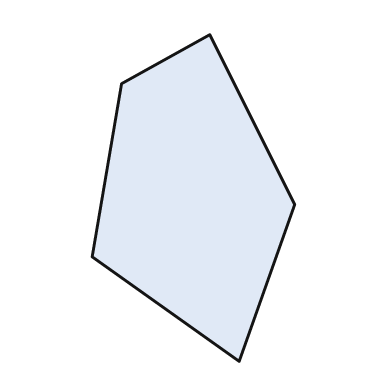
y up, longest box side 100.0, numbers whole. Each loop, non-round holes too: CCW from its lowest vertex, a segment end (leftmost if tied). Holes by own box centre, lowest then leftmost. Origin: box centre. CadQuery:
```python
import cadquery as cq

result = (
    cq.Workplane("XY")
    .moveTo(14.0, -50.0)
    .lineTo(31.0, -2.0)
    .lineTo(5.0, 50.0)
    .lineTo(-22.0, 35.0)
    .lineTo(-31.0, -18.0)
    .close()
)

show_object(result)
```